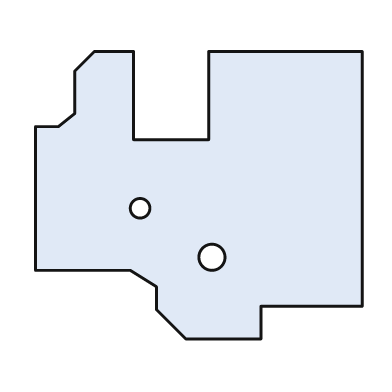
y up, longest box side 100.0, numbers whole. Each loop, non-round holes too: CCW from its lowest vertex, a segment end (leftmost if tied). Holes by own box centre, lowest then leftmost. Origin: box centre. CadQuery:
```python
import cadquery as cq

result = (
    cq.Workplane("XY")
    .moveTo(-4.0, -44.0)
    .lineTo(19.0, -44.0)
    .lineTo(19.0, -34.0)
    .lineTo(50.0, -34.0)
    .lineTo(50.0, 44.0)
    .lineTo(3.0, 44.0)
    .lineTo(3.0, 17.0)
    .lineTo(-20.0, 17.0)
    .lineTo(-20.0, 44.0)
    .lineTo(-32.0, 44.0)
    .lineTo(-38.0, 38.0)
    .lineTo(-38.0, 25.0)
    .lineTo(-43.0, 21.0)
    .lineTo(-50.0, 21.0)
    .lineTo(-50.0, -23.0)
    .lineTo(-21.0, -23.0)
    .lineTo(-13.0, -28.0)
    .lineTo(-13.0, -35.0)
    .close()
    .moveTo(4.0, -19.0)
    .circle(4.0)
    .moveTo(-18.0, -4.0)
    .circle(3.0)
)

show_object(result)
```